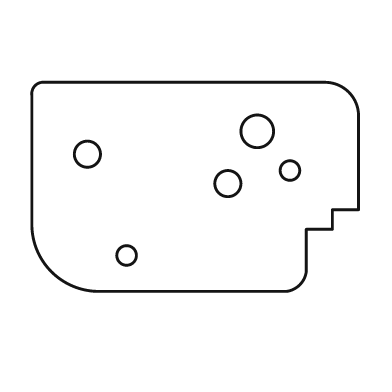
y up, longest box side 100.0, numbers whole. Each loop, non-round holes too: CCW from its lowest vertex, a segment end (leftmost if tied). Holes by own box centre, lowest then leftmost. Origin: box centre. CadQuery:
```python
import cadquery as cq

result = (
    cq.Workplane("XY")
    .moveTo(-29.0, -32.0)
    .lineTo(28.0, -32.0)
    .threePointArc((32.0, -30.0), (34.0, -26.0))
    .lineTo(34.0, -13.0)
    .lineTo(42.0, -13.0)
    .lineTo(42.0, -7.0)
    .lineTo(50.0, -7.0)
    .lineTo(50.0, 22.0)
    .threePointArc((47.0, 29.0), (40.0, 32.0))
    .lineTo(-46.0, 32.0)
    .threePointArc((-49.0, 31.0), (-50.0, 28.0))
    .lineTo(-50.0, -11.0)
    .threePointArc((-44.0, -26.0), (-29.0, -32.0))
    .close()
    .moveTo(-21.0, -21.0)
    .circle(3.0)
    .moveTo(10.0, 1.0)
    .circle(4.0)
    .moveTo(29.0, 5.0)
    .circle(3.0)
    .moveTo(-33.0, 10.0)
    .circle(4.0)
    .moveTo(19.0, 17.0)
    .circle(5.0)
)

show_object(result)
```